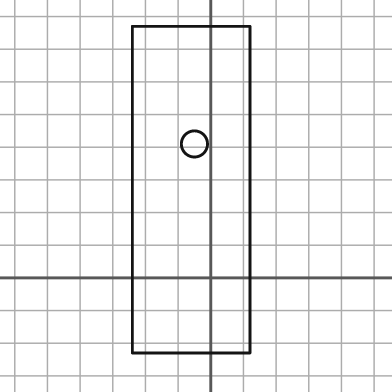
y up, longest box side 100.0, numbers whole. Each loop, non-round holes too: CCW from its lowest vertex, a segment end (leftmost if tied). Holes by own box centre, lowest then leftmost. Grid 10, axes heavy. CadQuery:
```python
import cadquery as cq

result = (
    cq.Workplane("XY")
    .moveTo(-24.0, -23.0)
    .lineTo(12.0, -23.0)
    .lineTo(12.0, 77.0)
    .lineTo(-24.0, 77.0)
    .close()
    .moveTo(-5.0, 41.0)
    .circle(4.0)
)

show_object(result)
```